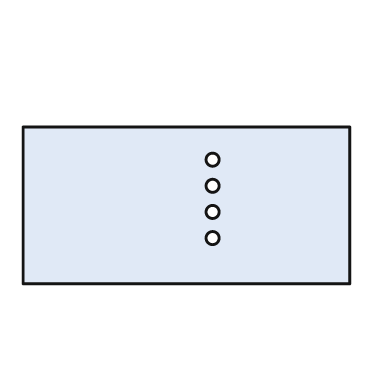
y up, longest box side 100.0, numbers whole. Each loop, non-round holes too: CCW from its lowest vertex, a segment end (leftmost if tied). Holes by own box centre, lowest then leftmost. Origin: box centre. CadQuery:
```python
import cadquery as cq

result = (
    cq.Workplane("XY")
    .moveTo(-50.0, -24.0)
    .lineTo(50.0, -24.0)
    .lineTo(50.0, 24.0)
    .lineTo(-50.0, 24.0)
    .close()
    .moveTo(8.0, -10.0)
    .circle(2.0)
    .moveTo(8.0, -2.0)
    .circle(2.0)
    .moveTo(8.0, 6.0)
    .circle(2.0)
    .moveTo(8.0, 14.0)
    .circle(2.0)
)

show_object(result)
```